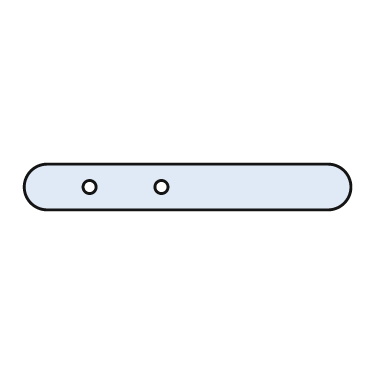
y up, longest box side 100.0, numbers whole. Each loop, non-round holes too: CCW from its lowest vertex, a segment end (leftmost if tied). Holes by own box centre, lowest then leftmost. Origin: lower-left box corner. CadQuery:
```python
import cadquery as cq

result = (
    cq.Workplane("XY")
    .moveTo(7.0, 0.0)
    .lineTo(93.0, 0.0)
    .threePointArc((100.0, 7.0), (93.0, 14.0))
    .lineTo(7.0, 14.0)
    .threePointArc((0.0, 7.0), (7.0, 0.0))
    .close()
    .moveTo(20.0, 7.0)
    .circle(2.0)
    .moveTo(42.0, 7.0)
    .circle(2.0)
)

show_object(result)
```